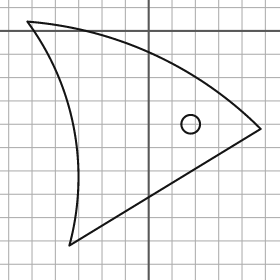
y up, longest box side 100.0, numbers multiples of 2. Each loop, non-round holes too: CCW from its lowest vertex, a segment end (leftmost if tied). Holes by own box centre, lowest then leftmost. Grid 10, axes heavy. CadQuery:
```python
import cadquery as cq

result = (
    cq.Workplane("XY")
    .moveTo(-34.0, -92.0)
    .lineTo(48.0, -42.0)
    .threePointArc((2.0, -10.0), (-52.0, 4.0))
    .threePointArc((-32.0, -42.0), (-34.0, -92.0))
    .close()
    .moveTo(18.0, -40.0)
    .circle(4.0)
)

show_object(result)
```